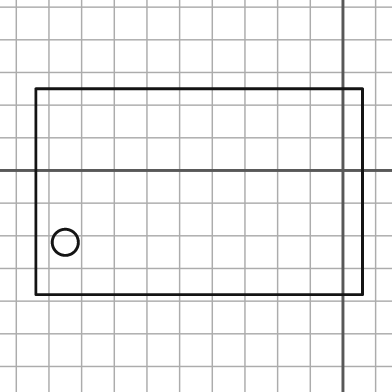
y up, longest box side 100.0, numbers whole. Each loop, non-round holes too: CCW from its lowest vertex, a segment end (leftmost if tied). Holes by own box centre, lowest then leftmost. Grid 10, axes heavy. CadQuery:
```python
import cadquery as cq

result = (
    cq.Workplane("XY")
    .moveTo(-94.0, -38.0)
    .lineTo(6.0, -38.0)
    .lineTo(6.0, 25.0)
    .lineTo(-94.0, 25.0)
    .close()
    .moveTo(-85.0, -22.0)
    .circle(4.0)
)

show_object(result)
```